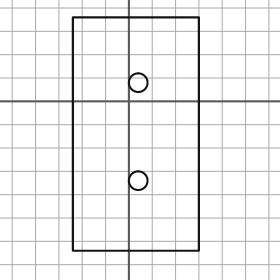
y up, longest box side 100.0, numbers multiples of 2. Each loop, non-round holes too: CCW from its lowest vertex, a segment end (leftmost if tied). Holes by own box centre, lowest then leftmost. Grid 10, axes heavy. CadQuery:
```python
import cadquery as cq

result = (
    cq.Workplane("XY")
    .moveTo(-24.0, -64.0)
    .lineTo(30.0, -64.0)
    .lineTo(30.0, 36.0)
    .lineTo(-24.0, 36.0)
    .close()
    .moveTo(4.0, -34.0)
    .circle(4.0)
    .moveTo(4.0, 8.0)
    .circle(4.0)
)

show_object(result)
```